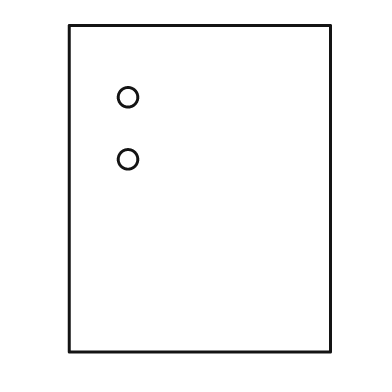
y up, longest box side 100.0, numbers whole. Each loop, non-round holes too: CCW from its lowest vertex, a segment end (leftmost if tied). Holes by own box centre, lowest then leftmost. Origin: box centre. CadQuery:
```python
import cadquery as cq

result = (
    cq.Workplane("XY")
    .moveTo(-40.0, -50.0)
    .lineTo(40.0, -50.0)
    .lineTo(40.0, 50.0)
    .lineTo(-40.0, 50.0)
    .close()
    .moveTo(-22.0, 9.0)
    .circle(3.0)
    .moveTo(-22.0, 28.0)
    .circle(3.0)
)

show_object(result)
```